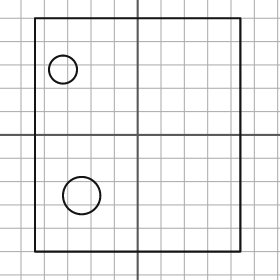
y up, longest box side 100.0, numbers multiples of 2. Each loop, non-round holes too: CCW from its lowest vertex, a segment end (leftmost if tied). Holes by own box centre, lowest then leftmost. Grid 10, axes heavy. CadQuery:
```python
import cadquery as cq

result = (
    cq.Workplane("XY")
    .moveTo(-44.0, -50.0)
    .lineTo(44.0, -50.0)
    .lineTo(44.0, 50.0)
    .lineTo(-44.0, 50.0)
    .close()
    .moveTo(-24.0, -26.0)
    .circle(8.0)
    .moveTo(-32.0, 28.0)
    .circle(6.0)
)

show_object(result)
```